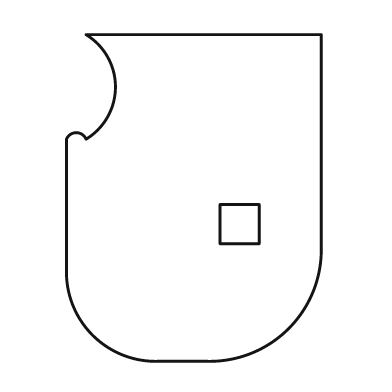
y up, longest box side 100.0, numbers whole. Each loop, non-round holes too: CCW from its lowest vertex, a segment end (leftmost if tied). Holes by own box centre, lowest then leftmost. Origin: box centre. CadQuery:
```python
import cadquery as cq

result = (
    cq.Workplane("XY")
    .moveTo(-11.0, -50.0)
    .lineTo(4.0, -50.0)
    .threePointArc((29.0, -40.0), (39.0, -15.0))
    .lineTo(39.0, 50.0)
    .lineTo(-33.0, 50.0)
    .threePointArc((-24.0, 34.0), (-33.0, 18.0))
    .threePointArc((-36.0, 20.0), (-39.0, 18.0))
    .lineTo(-39.0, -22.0)
    .threePointArc((-31.0, -42.0), (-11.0, -50.0))
    .close()
    .moveTo(8.0, -14.0)
    .lineTo(20.0, -14.0)
    .lineTo(20.0, -2.0)
    .lineTo(8.0, -2.0)
    .close()
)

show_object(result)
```